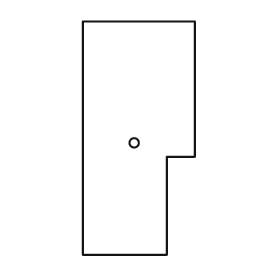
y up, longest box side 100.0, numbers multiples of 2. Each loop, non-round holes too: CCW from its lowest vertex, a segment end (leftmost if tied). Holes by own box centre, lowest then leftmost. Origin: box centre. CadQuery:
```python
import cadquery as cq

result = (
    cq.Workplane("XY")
    .moveTo(-24.0, -50.0)
    .lineTo(12.0, -50.0)
    .lineTo(12.0, -8.0)
    .lineTo(24.0, -8.0)
    .lineTo(24.0, 50.0)
    .lineTo(-24.0, 50.0)
    .close()
    .moveTo(-2.0, -2.0)
    .circle(2.0)
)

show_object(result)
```